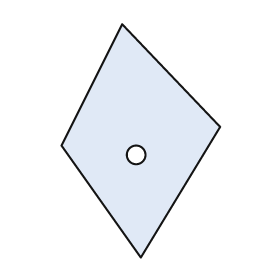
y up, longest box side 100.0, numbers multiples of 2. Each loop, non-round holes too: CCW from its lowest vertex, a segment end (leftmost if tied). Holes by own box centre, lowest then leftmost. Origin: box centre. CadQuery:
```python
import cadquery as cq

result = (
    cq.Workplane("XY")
    .moveTo(0.0, -50.0)
    .lineTo(34.0, 6.0)
    .lineTo(-8.0, 50.0)
    .lineTo(-34.0, -2.0)
    .close()
    .moveTo(-2.0, -6.0)
    .circle(4.0)
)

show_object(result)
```